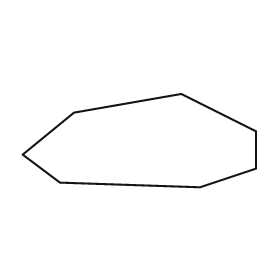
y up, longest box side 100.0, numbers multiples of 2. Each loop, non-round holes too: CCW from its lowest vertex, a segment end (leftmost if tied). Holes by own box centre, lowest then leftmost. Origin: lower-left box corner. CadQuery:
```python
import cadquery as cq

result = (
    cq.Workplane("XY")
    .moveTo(76.0, 0.0)
    .lineTo(100.0, 8.0)
    .lineTo(100.0, 24.0)
    .lineTo(68.0, 40.0)
    .lineTo(22.0, 32.0)
    .lineTo(0.0, 14.0)
    .lineTo(16.0, 2.0)
    .close()
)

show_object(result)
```